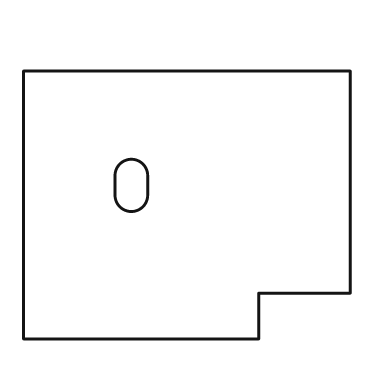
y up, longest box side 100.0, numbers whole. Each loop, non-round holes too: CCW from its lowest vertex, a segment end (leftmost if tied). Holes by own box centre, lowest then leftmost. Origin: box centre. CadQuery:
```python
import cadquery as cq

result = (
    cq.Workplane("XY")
    .moveTo(-50.0, -41.0)
    .lineTo(22.0, -41.0)
    .lineTo(22.0, -27.0)
    .lineTo(50.0, -27.0)
    .lineTo(50.0, 41.0)
    .lineTo(-50.0, 41.0)
    .close()
    .moveTo(-22.0, 3.0)
    .threePointArc((-17.0, -2.0), (-12.0, 3.0))
    .lineTo(-12.0, 9.0)
    .threePointArc((-17.0, 14.0), (-22.0, 9.0))
    .close()
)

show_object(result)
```